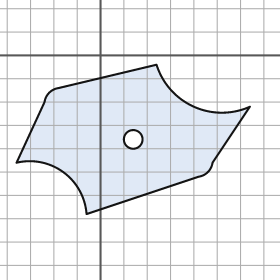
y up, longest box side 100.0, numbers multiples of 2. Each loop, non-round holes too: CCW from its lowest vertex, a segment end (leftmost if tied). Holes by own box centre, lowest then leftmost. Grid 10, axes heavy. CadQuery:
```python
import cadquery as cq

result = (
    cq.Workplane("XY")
    .moveTo(-6.0, -68.0)
    .lineTo(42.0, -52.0)
    .threePointArc((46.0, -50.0), (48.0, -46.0))
    .lineTo(64.0, -22.0)
    .threePointArc((40.0, -22.0), (24.0, -4.0))
    .lineTo(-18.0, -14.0)
    .threePointArc((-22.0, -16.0), (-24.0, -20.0))
    .lineTo(-36.0, -46.0)
    .threePointArc((-16.0, -50.0), (-6.0, -68.0))
    .close()
    .moveTo(14.0, -36.0)
    .circle(4.0)
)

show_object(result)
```